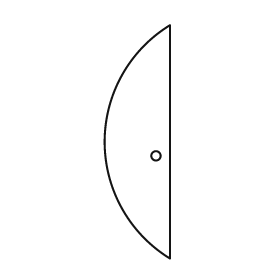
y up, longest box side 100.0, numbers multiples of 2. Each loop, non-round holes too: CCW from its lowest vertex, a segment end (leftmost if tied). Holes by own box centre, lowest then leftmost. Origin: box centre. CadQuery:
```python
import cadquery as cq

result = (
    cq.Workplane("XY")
    .moveTo(14.0, -50.0)
    .lineTo(14.0, 50.0)
    .threePointArc((-14.0, 0.0), (14.0, -50.0))
    .close()
    .moveTo(8.0, -6.0)
    .circle(2.0)
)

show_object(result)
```